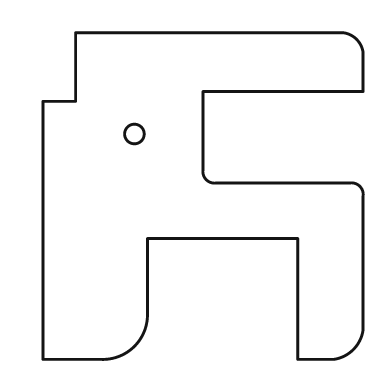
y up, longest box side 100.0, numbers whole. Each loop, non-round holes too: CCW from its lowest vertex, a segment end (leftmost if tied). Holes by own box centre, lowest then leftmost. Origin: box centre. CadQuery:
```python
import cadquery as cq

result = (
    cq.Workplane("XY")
    .moveTo(-49.0, -50.0)
    .lineTo(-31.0, -50.0)
    .threePointArc((-21.0, -46.0), (-17.0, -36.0))
    .lineTo(-17.0, -13.0)
    .lineTo(29.0, -13.0)
    .lineTo(29.0, -50.0)
    .lineTo(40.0, -50.0)
    .threePointArc((46.0, -47.0), (49.0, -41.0))
    .lineTo(49.0, 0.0)
    .threePointArc((48.0, 3.0), (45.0, 4.0))
    .lineTo(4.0, 4.0)
    .threePointArc((1.0, 5.0), (0.0, 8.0))
    .lineTo(0.0, 32.0)
    .lineTo(49.0, 32.0)
    .lineTo(49.0, 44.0)
    .threePointArc((47.0, 48.0), (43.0, 50.0))
    .lineTo(-39.0, 50.0)
    .lineTo(-39.0, 29.0)
    .lineTo(-49.0, 29.0)
    .close()
    .moveTo(-21.0, 19.0)
    .circle(3.0)
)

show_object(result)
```